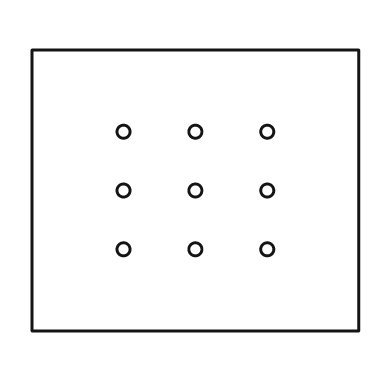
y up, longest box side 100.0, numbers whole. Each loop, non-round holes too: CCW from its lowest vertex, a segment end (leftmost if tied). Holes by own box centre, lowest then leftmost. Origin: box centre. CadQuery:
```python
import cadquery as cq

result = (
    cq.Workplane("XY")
    .moveTo(-50.0, -43.0)
    .lineTo(50.0, -43.0)
    .lineTo(50.0, 43.0)
    .lineTo(-50.0, 43.0)
    .close()
    .moveTo(-22.0, -18.0)
    .circle(2.0)
    .moveTo(0.0, -18.0)
    .circle(2.0)
    .moveTo(22.0, -18.0)
    .circle(2.0)
    .moveTo(-22.0, 0.0)
    .circle(2.0)
    .moveTo(0.0, 0.0)
    .circle(2.0)
    .moveTo(22.0, 0.0)
    .circle(2.0)
    .moveTo(-22.0, 18.0)
    .circle(2.0)
    .moveTo(0.0, 18.0)
    .circle(2.0)
    .moveTo(22.0, 18.0)
    .circle(2.0)
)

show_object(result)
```